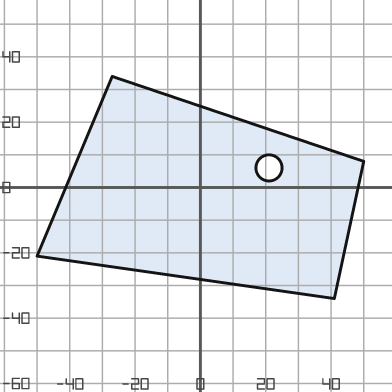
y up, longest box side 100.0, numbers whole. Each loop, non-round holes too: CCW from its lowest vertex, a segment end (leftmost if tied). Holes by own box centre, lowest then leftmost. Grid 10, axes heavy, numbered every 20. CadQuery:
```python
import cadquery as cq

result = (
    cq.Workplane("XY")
    .moveTo(41.0, -34.0)
    .lineTo(50.0, 8.0)
    .lineTo(-27.0, 34.0)
    .lineTo(-50.0, -21.0)
    .close()
    .moveTo(21.0, 6.0)
    .circle(4.0)
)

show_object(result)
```